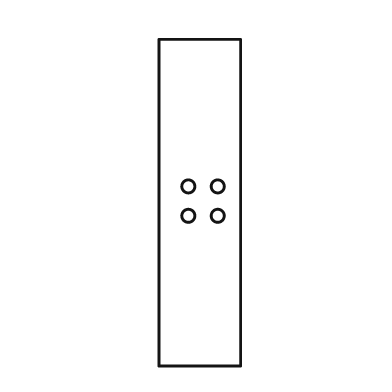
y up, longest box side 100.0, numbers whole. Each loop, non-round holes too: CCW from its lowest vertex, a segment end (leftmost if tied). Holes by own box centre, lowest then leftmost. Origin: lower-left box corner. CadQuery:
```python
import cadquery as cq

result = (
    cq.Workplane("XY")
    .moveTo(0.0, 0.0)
    .lineTo(25.0, 0.0)
    .lineTo(25.0, 100.0)
    .lineTo(0.0, 100.0)
    .close()
    .moveTo(9.0, 46.0)
    .circle(2.0)
    .moveTo(18.0, 46.0)
    .circle(2.0)
    .moveTo(9.0, 55.0)
    .circle(2.0)
    .moveTo(18.0, 55.0)
    .circle(2.0)
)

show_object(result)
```